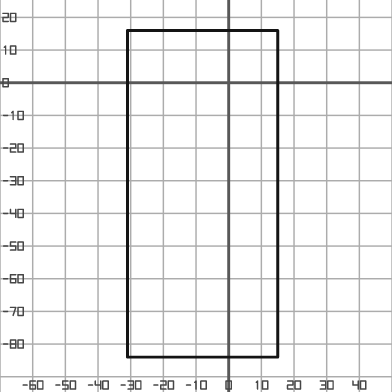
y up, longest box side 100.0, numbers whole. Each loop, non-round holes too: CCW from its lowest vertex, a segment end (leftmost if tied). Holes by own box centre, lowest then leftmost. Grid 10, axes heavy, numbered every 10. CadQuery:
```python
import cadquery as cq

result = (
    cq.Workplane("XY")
    .moveTo(-31.0, -84.0)
    .lineTo(15.0, -84.0)
    .lineTo(15.0, 16.0)
    .lineTo(-31.0, 16.0)
    .close()
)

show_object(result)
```